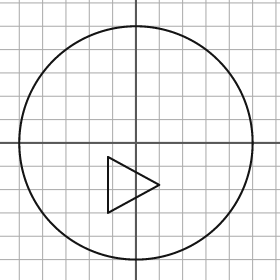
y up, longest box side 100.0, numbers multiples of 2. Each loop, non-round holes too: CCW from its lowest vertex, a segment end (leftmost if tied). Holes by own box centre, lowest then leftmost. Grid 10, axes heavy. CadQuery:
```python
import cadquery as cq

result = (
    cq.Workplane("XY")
    .moveTo(0.0, 0.0)
    .circle(50.0)
    .moveTo(-12.0, -30.0)
    .lineTo(10.0, -18.0)
    .lineTo(-12.0, -6.0)
    .close()
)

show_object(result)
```